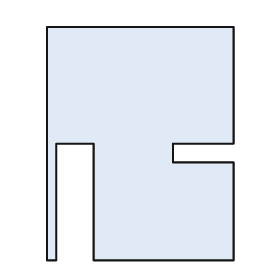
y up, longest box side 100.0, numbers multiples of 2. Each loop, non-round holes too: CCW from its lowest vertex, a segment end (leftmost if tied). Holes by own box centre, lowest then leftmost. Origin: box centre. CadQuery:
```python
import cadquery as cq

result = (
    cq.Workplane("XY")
    .moveTo(-40.0, -50.0)
    .lineTo(-36.0, -50.0)
    .lineTo(-36.0, 0.0)
    .lineTo(-20.0, 0.0)
    .lineTo(-20.0, -50.0)
    .lineTo(40.0, -50.0)
    .lineTo(40.0, -8.0)
    .lineTo(14.0, -8.0)
    .lineTo(14.0, 0.0)
    .lineTo(40.0, 0.0)
    .lineTo(40.0, 50.0)
    .lineTo(-40.0, 50.0)
    .close()
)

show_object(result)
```